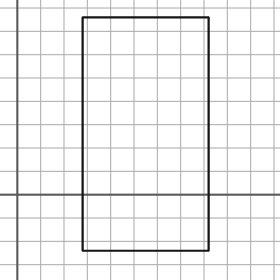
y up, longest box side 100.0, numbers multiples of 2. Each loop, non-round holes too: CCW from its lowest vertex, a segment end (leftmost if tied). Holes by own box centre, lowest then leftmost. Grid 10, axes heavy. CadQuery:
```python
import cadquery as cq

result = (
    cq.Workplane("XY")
    .moveTo(28.0, -24.0)
    .lineTo(82.0, -24.0)
    .lineTo(82.0, 76.0)
    .lineTo(28.0, 76.0)
    .close()
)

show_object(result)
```